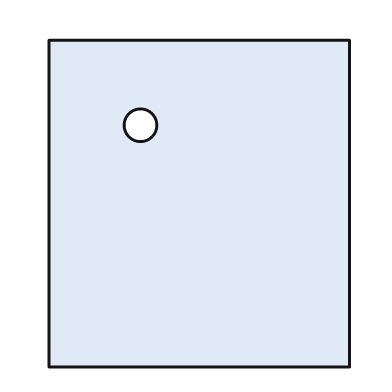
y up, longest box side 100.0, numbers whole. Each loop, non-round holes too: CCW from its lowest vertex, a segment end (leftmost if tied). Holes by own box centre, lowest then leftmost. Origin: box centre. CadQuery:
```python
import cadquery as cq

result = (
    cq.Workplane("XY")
    .moveTo(-46.0, -50.0)
    .lineTo(46.0, -50.0)
    .lineTo(46.0, 50.0)
    .lineTo(-46.0, 50.0)
    .close()
    .moveTo(-18.0, 24.0)
    .circle(5.0)
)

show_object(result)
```